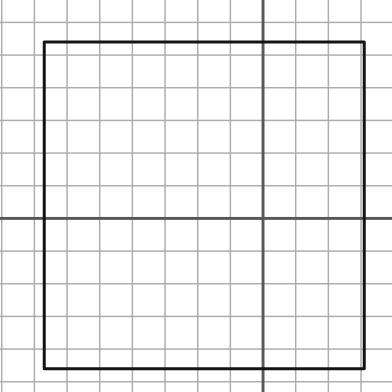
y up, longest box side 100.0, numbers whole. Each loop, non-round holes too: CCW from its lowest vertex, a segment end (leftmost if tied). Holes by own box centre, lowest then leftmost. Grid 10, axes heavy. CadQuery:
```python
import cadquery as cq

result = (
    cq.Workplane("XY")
    .moveTo(-67.0, -46.0)
    .lineTo(31.0, -46.0)
    .lineTo(31.0, 54.0)
    .lineTo(-67.0, 54.0)
    .close()
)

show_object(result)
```